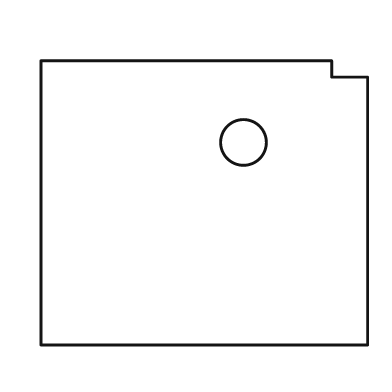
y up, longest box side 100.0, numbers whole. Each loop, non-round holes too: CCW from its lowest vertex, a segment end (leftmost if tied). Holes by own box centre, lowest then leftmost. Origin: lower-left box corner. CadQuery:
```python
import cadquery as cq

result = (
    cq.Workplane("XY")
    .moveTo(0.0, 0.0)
    .lineTo(100.0, 0.0)
    .lineTo(100.0, 82.0)
    .lineTo(89.0, 82.0)
    .lineTo(89.0, 87.0)
    .lineTo(0.0, 87.0)
    .close()
    .moveTo(62.0, 62.0)
    .circle(7.0)
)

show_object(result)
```